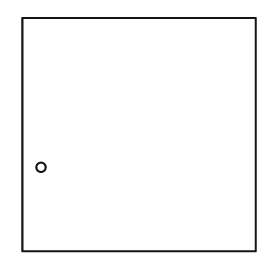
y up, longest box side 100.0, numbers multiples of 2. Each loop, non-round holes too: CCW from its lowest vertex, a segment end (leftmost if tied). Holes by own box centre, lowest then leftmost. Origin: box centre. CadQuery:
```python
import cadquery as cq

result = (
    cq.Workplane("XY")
    .moveTo(-50.0, -50.0)
    .lineTo(50.0, -50.0)
    .lineTo(50.0, 50.0)
    .lineTo(-50.0, 50.0)
    .close()
    .moveTo(-42.0, -14.0)
    .circle(2.0)
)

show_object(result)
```